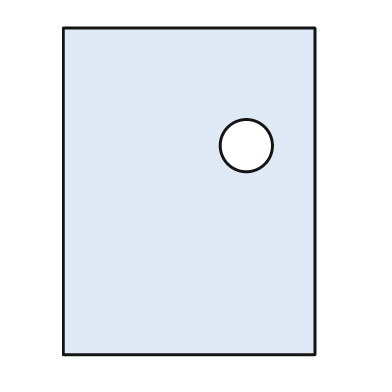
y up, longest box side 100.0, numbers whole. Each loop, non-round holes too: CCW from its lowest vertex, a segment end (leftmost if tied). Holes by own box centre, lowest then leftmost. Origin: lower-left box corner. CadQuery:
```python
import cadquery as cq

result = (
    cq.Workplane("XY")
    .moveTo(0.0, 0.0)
    .lineTo(77.0, 0.0)
    .lineTo(77.0, 100.0)
    .lineTo(0.0, 100.0)
    .close()
    .moveTo(56.0, 64.0)
    .circle(8.0)
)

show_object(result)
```